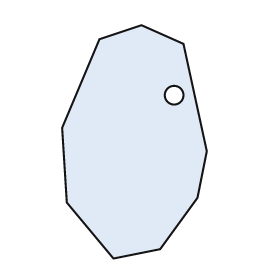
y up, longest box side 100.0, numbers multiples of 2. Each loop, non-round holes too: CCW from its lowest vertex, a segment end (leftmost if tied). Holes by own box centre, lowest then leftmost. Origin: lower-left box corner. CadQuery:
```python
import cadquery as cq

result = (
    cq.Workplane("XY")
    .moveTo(22.0, 0.0)
    .lineTo(42.0, 4.0)
    .lineTo(58.0, 26.0)
    .lineTo(62.0, 46.0)
    .lineTo(52.0, 92.0)
    .lineTo(34.0, 100.0)
    .lineTo(16.0, 94.0)
    .lineTo(0.0, 56.0)
    .lineTo(2.0, 24.0)
    .close()
    .moveTo(48.0, 70.0)
    .circle(4.0)
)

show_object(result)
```